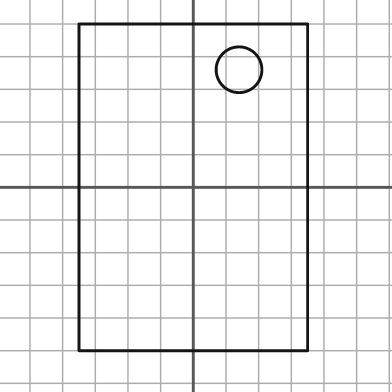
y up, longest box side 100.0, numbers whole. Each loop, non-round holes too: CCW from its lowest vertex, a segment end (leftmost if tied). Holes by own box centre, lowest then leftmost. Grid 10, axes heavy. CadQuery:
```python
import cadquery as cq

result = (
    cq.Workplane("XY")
    .moveTo(-35.0, -50.0)
    .lineTo(35.0, -50.0)
    .lineTo(35.0, 50.0)
    .lineTo(-35.0, 50.0)
    .close()
    .moveTo(14.0, 36.0)
    .circle(7.0)
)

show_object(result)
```